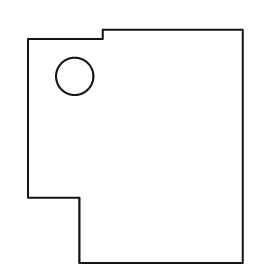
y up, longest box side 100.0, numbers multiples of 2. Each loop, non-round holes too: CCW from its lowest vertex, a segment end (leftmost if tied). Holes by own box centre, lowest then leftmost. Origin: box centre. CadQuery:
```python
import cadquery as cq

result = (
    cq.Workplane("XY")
    .moveTo(-24.0, -50.0)
    .lineTo(46.0, -50.0)
    .lineTo(46.0, 50.0)
    .lineTo(-14.0, 50.0)
    .lineTo(-14.0, 46.0)
    .lineTo(-46.0, 46.0)
    .lineTo(-46.0, -22.0)
    .lineTo(-24.0, -22.0)
    .close()
    .moveTo(-26.0, 30.0)
    .circle(8.0)
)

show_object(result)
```